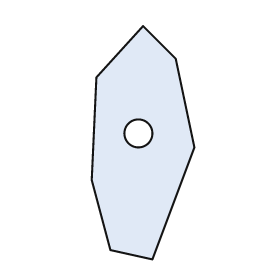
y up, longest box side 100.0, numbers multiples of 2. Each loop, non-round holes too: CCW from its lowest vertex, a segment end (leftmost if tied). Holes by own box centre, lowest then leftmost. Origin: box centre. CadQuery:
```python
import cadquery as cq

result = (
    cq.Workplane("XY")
    .moveTo(4.0, -50.0)
    .lineTo(22.0, -2.0)
    .lineTo(14.0, 36.0)
    .lineTo(0.0, 50.0)
    .lineTo(-20.0, 28.0)
    .lineTo(-22.0, -16.0)
    .lineTo(-14.0, -46.0)
    .close()
    .moveTo(-2.0, 4.0)
    .circle(6.0)
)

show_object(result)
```